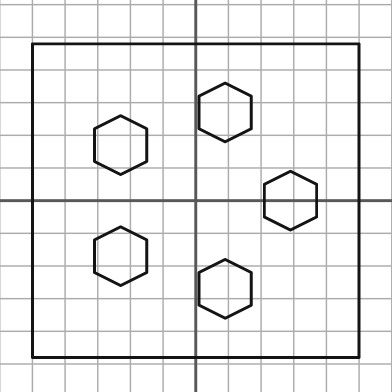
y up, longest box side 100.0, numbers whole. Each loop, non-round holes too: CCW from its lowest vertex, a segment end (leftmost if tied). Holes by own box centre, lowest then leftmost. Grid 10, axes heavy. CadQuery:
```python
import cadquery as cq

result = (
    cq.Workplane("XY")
    .moveTo(-50.0, -48.0)
    .lineTo(50.0, -48.0)
    .lineTo(50.0, 48.0)
    .lineTo(-50.0, 48.0)
    .close()
    .moveTo(9.0, -36.0)
    .lineTo(17.0, -32.0)
    .lineTo(17.0, -22.0)
    .lineTo(9.0, -18.0)
    .lineTo(1.0, -22.0)
    .lineTo(1.0, -32.0)
    .close()
    .moveTo(-23.0, -26.0)
    .lineTo(-15.0, -22.0)
    .lineTo(-15.0, -12.0)
    .lineTo(-23.0, -8.0)
    .lineTo(-31.0, -12.0)
    .lineTo(-31.0, -22.0)
    .close()
    .moveTo(29.0, -9.0)
    .lineTo(37.0, -5.0)
    .lineTo(37.0, 5.0)
    .lineTo(29.0, 9.0)
    .lineTo(21.0, 5.0)
    .lineTo(21.0, -5.0)
    .close()
    .moveTo(-23.0, 8.0)
    .lineTo(-15.0, 12.0)
    .lineTo(-15.0, 22.0)
    .lineTo(-23.0, 26.0)
    .lineTo(-31.0, 22.0)
    .lineTo(-31.0, 12.0)
    .close()
    .moveTo(9.0, 18.0)
    .lineTo(17.0, 22.0)
    .lineTo(17.0, 32.0)
    .lineTo(9.0, 36.0)
    .lineTo(1.0, 32.0)
    .lineTo(1.0, 22.0)
    .close()
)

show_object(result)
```